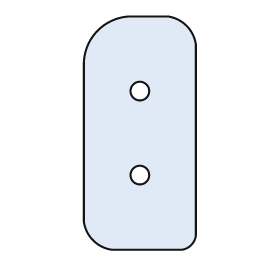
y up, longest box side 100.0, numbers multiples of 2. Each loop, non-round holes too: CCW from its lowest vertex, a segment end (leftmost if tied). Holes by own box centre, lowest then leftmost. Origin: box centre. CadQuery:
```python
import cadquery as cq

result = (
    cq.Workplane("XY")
    .moveTo(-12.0, -50.0)
    .lineTo(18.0, -50.0)
    .threePointArc((22.0, -48.0), (24.0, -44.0))
    .lineTo(24.0, 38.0)
    .threePointArc((20.0, 46.0), (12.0, 50.0))
    .lineTo(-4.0, 50.0)
    .threePointArc((-18.0, 44.0), (-24.0, 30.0))
    .lineTo(-24.0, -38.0)
    .threePointArc((-20.0, -46.0), (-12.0, -50.0))
    .close()
    .moveTo(0.0, -18.0)
    .circle(4.0)
    .moveTo(0.0, 18.0)
    .circle(4.0)
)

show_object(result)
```